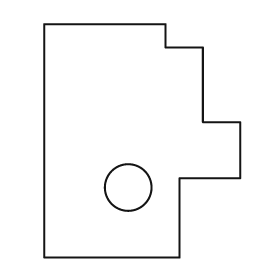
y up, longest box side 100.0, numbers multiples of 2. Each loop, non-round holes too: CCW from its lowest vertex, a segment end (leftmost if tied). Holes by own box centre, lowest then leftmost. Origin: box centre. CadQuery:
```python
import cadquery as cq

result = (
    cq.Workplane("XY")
    .moveTo(-42.0, -50.0)
    .lineTo(16.0, -50.0)
    .lineTo(16.0, -16.0)
    .lineTo(42.0, -16.0)
    .lineTo(42.0, 8.0)
    .lineTo(26.0, 8.0)
    .lineTo(26.0, 40.0)
    .lineTo(10.0, 40.0)
    .lineTo(10.0, 50.0)
    .lineTo(-42.0, 50.0)
    .close()
    .moveTo(-6.0, -20.0)
    .circle(10.0)
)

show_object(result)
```